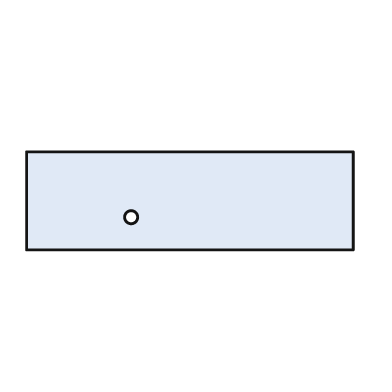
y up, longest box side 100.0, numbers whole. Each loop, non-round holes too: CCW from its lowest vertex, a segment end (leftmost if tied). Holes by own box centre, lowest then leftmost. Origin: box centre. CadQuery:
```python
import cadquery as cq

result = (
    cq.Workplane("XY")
    .moveTo(-50.0, -15.0)
    .lineTo(50.0, -15.0)
    .lineTo(50.0, 15.0)
    .lineTo(-50.0, 15.0)
    .close()
    .moveTo(-18.0, -5.0)
    .circle(2.0)
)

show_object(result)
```